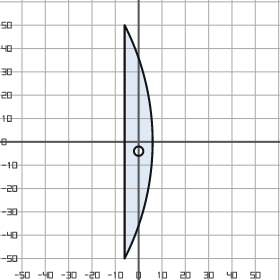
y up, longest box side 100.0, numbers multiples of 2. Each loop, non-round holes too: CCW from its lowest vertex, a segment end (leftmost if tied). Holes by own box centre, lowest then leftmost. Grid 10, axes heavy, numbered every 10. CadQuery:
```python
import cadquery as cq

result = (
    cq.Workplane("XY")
    .moveTo(-6.0, -50.0)
    .threePointArc((6.0, 0.0), (-6.0, 50.0))
    .close()
    .moveTo(0.0, -4.0)
    .circle(2.0)
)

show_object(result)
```